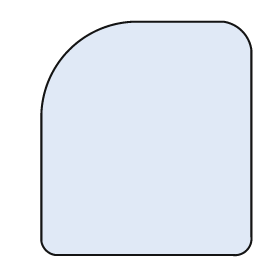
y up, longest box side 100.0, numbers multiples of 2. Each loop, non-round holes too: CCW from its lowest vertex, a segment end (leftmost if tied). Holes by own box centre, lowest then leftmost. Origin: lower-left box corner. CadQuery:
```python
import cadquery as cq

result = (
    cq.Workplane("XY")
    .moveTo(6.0, 0.0)
    .lineTo(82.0, 0.0)
    .threePointArc((88.0, 2.0), (90.0, 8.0))
    .lineTo(90.0, 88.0)
    .threePointArc((86.0, 96.0), (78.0, 100.0))
    .lineTo(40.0, 100.0)
    .threePointArc((12.0, 88.0), (0.0, 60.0))
    .lineTo(0.0, 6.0)
    .threePointArc((2.0, 2.0), (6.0, 0.0))
    .close()
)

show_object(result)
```